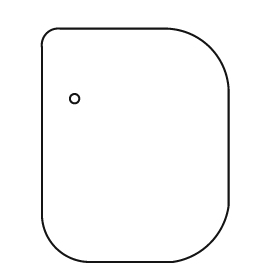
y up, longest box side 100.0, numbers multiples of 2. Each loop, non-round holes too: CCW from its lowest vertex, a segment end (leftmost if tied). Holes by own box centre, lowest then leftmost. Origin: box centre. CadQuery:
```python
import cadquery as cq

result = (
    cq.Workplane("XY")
    .moveTo(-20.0, -50.0)
    .lineTo(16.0, -50.0)
    .threePointArc((32.0, -42.0), (40.0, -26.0))
    .lineTo(40.0, 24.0)
    .threePointArc((32.0, 42.0), (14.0, 50.0))
    .lineTo(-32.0, 50.0)
    .threePointArc((-38.0, 48.0), (-40.0, 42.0))
    .lineTo(-40.0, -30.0)
    .threePointArc((-34.0, -44.0), (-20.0, -50.0))
    .close()
    .moveTo(-26.0, 20.0)
    .circle(2.0)
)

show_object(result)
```